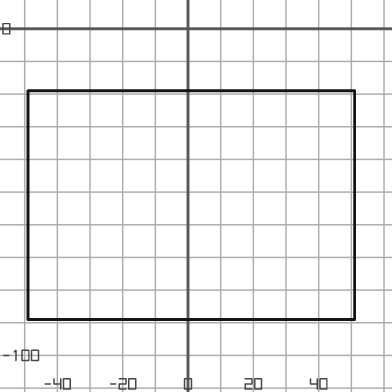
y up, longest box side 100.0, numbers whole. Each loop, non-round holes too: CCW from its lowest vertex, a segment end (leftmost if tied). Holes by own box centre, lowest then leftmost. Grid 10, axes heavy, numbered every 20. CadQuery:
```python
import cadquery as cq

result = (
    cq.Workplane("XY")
    .moveTo(-49.0, -89.0)
    .lineTo(51.0, -89.0)
    .lineTo(51.0, -19.0)
    .lineTo(-49.0, -19.0)
    .close()
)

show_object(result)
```